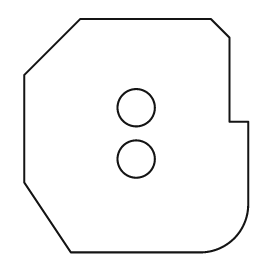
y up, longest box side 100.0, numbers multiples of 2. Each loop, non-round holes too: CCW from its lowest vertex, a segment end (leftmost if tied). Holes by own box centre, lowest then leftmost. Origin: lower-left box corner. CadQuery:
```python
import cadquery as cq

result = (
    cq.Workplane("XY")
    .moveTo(20.0, 0.0)
    .lineTo(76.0, 0.0)
    .threePointArc((90.0, 6.0), (96.0, 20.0))
    .lineTo(96.0, 56.0)
    .lineTo(88.0, 56.0)
    .lineTo(88.0, 92.0)
    .lineTo(80.0, 100.0)
    .lineTo(24.0, 100.0)
    .lineTo(0.0, 76.0)
    .lineTo(0.0, 30.0)
    .close()
    .moveTo(48.0, 40.0)
    .circle(8.0)
    .moveTo(48.0, 62.0)
    .circle(8.0)
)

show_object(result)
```